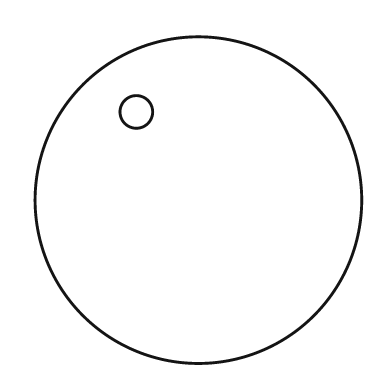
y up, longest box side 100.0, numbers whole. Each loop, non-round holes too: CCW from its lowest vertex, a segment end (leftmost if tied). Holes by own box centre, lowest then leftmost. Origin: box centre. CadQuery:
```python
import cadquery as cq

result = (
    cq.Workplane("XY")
    .moveTo(0.0, 0.0)
    .circle(50.0)
    .moveTo(-19.0, 27.0)
    .circle(5.0)
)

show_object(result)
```